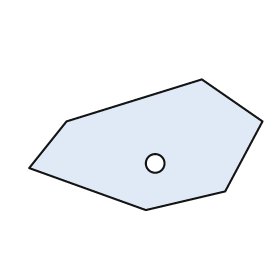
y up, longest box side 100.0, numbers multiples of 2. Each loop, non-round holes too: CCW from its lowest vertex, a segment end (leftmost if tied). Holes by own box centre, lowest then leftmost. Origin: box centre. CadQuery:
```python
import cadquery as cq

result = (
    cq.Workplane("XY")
    .moveTo(0.0, -28.0)
    .lineTo(34.0, -20.0)
    .lineTo(50.0, 10.0)
    .lineTo(24.0, 28.0)
    .lineTo(-34.0, 10.0)
    .lineTo(-50.0, -10.0)
    .close()
    .moveTo(4.0, -8.0)
    .circle(4.0)
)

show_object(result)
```